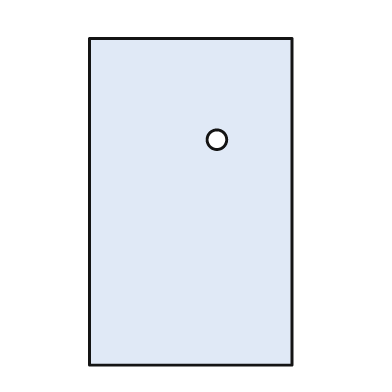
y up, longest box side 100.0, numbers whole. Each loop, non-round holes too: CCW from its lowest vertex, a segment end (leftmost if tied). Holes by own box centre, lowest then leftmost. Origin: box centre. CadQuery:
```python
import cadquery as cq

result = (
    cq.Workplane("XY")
    .moveTo(-31.0, -50.0)
    .lineTo(31.0, -50.0)
    .lineTo(31.0, 50.0)
    .lineTo(-31.0, 50.0)
    .close()
    .moveTo(8.0, 19.0)
    .circle(3.0)
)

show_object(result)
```